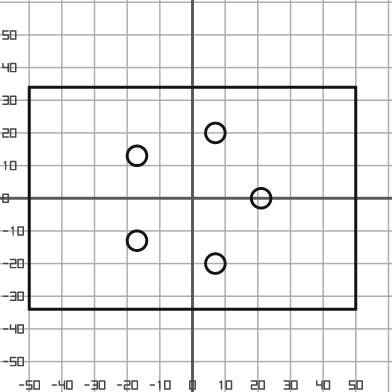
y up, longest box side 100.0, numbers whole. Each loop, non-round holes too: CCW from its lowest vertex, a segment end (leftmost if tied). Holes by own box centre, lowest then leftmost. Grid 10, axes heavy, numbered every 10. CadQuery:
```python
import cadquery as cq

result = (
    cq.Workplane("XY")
    .moveTo(-50.0, -34.0)
    .lineTo(50.0, -34.0)
    .lineTo(50.0, 34.0)
    .lineTo(-50.0, 34.0)
    .close()
    .moveTo(7.0, -20.0)
    .circle(3.0)
    .moveTo(-17.0, -13.0)
    .circle(3.0)
    .moveTo(21.0, 0.0)
    .circle(3.0)
    .moveTo(-17.0, 13.0)
    .circle(3.0)
    .moveTo(7.0, 20.0)
    .circle(3.0)
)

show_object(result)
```